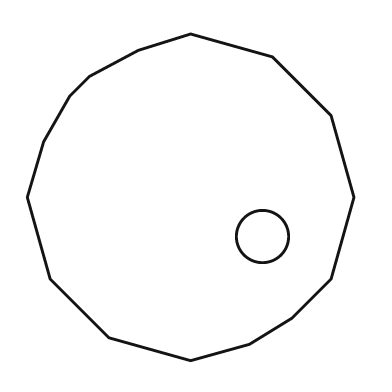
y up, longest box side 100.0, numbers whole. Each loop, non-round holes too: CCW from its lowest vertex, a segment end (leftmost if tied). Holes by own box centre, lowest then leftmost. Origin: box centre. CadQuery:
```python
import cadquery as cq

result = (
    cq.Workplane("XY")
    .moveTo(0.0, -50.0)
    .lineTo(18.0, -45.0)
    .lineTo(31.0, -37.0)
    .lineTo(43.0, -25.0)
    .lineTo(50.0, 0.0)
    .lineTo(43.0, 25.0)
    .lineTo(25.0, 43.0)
    .lineTo(0.0, 50.0)
    .lineTo(-16.0, 45.0)
    .lineTo(-31.0, 37.0)
    .lineTo(-37.0, 31.0)
    .lineTo(-45.0, 17.0)
    .lineTo(-50.0, 0.0)
    .lineTo(-43.0, -25.0)
    .lineTo(-25.0, -43.0)
    .close()
    .moveTo(22.0, -12.0)
    .circle(8.0)
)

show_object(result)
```